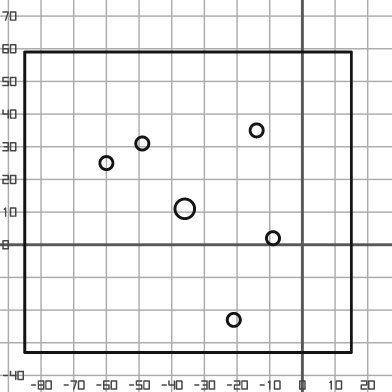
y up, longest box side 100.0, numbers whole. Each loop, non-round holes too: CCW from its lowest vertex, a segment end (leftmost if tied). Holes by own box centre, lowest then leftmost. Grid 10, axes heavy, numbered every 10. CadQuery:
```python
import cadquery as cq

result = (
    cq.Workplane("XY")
    .moveTo(-85.0, -33.0)
    .lineTo(15.0, -33.0)
    .lineTo(15.0, 59.0)
    .lineTo(-85.0, 59.0)
    .close()
    .moveTo(-21.0, -23.0)
    .circle(2.0)
    .moveTo(-9.0, 2.0)
    .circle(2.0)
    .moveTo(-36.0, 11.0)
    .circle(3.0)
    .moveTo(-60.0, 25.0)
    .circle(2.0)
    .moveTo(-49.0, 31.0)
    .circle(2.0)
    .moveTo(-14.0, 35.0)
    .circle(2.0)
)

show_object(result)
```